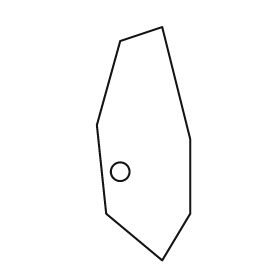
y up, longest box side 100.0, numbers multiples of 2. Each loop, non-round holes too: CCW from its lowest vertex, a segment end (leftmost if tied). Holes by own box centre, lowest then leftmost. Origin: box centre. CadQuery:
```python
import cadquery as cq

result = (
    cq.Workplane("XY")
    .moveTo(8.0, -50.0)
    .lineTo(20.0, -30.0)
    .lineTo(20.0, 2.0)
    .lineTo(8.0, 50.0)
    .lineTo(-10.0, 44.0)
    .lineTo(-20.0, 8.0)
    .lineTo(-16.0, -30.0)
    .close()
    .moveTo(-10.0, -12.0)
    .circle(4.0)
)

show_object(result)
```